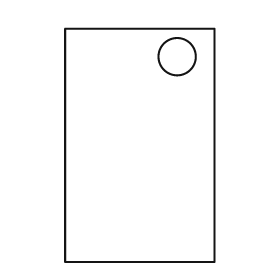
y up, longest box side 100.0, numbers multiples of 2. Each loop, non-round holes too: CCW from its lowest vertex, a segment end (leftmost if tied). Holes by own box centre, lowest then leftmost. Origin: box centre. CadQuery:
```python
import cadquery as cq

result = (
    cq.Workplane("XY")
    .moveTo(-32.0, -50.0)
    .lineTo(32.0, -50.0)
    .lineTo(32.0, 50.0)
    .lineTo(-32.0, 50.0)
    .close()
    .moveTo(16.0, 38.0)
    .circle(8.0)
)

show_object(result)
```